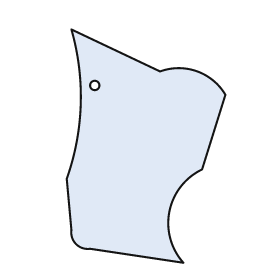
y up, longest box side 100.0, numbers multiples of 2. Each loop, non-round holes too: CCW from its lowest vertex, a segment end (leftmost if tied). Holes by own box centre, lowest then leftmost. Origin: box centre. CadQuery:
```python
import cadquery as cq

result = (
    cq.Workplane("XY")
    .moveTo(16.0, -50.0)
    .threePointArc((10.0, -28.0), (24.0, -10.0))
    .lineTo(34.0, 22.0)
    .threePointArc((22.0, 32.0), (6.0, 32.0))
    .lineTo(-32.0, 50.0)
    .threePointArc((-28.0, 18.0), (-34.0, -14.0))
    .lineTo(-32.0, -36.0)
    .threePointArc((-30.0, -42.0), (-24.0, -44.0))
    .close()
    .moveTo(-22.0, 26.0)
    .circle(2.0)
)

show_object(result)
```